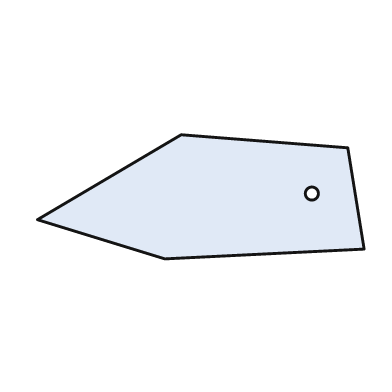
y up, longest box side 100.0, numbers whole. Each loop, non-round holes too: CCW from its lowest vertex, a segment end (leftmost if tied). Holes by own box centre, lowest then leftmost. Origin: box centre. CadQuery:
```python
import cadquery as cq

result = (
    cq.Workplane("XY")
    .moveTo(-11.0, -19.0)
    .lineTo(50.0, -16.0)
    .lineTo(45.0, 15.0)
    .lineTo(-6.0, 19.0)
    .lineTo(-50.0, -7.0)
    .close()
    .moveTo(34.0, 1.0)
    .circle(2.0)
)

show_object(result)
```